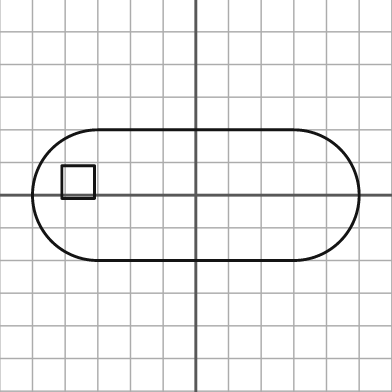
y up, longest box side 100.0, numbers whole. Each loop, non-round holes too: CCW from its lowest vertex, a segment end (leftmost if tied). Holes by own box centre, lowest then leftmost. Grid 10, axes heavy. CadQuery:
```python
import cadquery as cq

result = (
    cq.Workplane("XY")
    .moveTo(-30.0, -20.0)
    .lineTo(30.0, -20.0)
    .threePointArc((50.0, 0.0), (30.0, 20.0))
    .lineTo(-30.0, 20.0)
    .threePointArc((-50.0, 0.0), (-30.0, -20.0))
    .close()
    .moveTo(-41.0, -1.0)
    .lineTo(-31.0, -1.0)
    .lineTo(-31.0, 9.0)
    .lineTo(-41.0, 9.0)
    .close()
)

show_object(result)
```